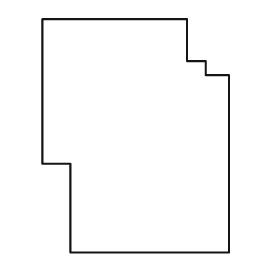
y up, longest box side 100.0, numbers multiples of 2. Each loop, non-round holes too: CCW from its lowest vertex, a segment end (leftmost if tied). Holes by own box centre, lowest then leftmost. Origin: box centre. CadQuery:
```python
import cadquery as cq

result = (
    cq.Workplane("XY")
    .moveTo(-28.0, -50.0)
    .lineTo(40.0, -50.0)
    .lineTo(40.0, 26.0)
    .lineTo(30.0, 26.0)
    .lineTo(30.0, 32.0)
    .lineTo(22.0, 32.0)
    .lineTo(22.0, 50.0)
    .lineTo(-40.0, 50.0)
    .lineTo(-40.0, -12.0)
    .lineTo(-28.0, -12.0)
    .close()
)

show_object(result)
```